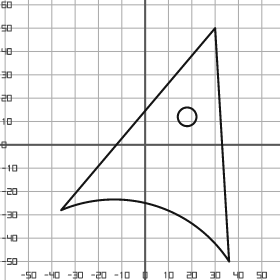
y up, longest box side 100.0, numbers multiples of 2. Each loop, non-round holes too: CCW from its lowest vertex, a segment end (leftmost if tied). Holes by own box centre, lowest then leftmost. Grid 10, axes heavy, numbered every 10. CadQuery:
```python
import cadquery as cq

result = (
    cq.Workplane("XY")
    .moveTo(36.0, -50.0)
    .lineTo(30.0, 50.0)
    .lineTo(-36.0, -28.0)
    .threePointArc((4.0, -26.0), (36.0, -50.0))
    .close()
    .moveTo(18.0, 12.0)
    .circle(4.0)
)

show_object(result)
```